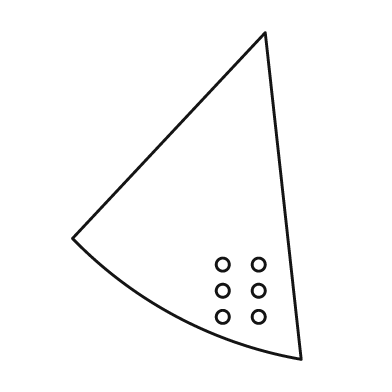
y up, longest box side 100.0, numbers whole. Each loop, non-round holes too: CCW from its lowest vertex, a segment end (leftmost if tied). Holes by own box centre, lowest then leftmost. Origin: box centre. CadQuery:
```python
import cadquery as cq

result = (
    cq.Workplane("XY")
    .moveTo(35.0, -50.0)
    .lineTo(24.0, 50.0)
    .lineTo(-35.0, -13.0)
    .threePointArc((-3.0, -37.0), (35.0, -50.0))
    .close()
    .moveTo(11.0, -37.0)
    .circle(2.0)
    .moveTo(22.0, -37.0)
    .circle(2.0)
    .moveTo(11.0, -29.0)
    .circle(2.0)
    .moveTo(22.0, -29.0)
    .circle(2.0)
    .moveTo(11.0, -21.0)
    .circle(2.0)
    .moveTo(22.0, -21.0)
    .circle(2.0)
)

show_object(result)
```